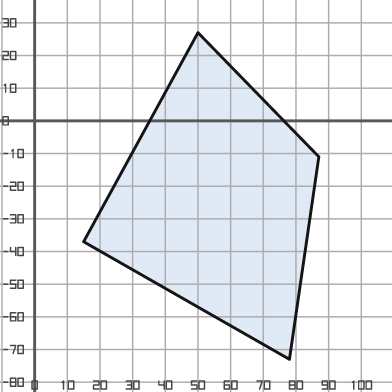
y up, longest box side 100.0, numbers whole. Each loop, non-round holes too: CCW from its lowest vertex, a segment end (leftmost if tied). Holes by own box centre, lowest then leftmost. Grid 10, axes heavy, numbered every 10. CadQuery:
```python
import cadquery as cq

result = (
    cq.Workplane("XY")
    .moveTo(78.0, -73.0)
    .lineTo(87.0, -11.0)
    .lineTo(50.0, 27.0)
    .lineTo(15.0, -37.0)
    .close()
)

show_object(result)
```